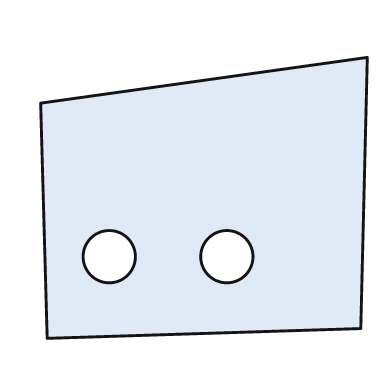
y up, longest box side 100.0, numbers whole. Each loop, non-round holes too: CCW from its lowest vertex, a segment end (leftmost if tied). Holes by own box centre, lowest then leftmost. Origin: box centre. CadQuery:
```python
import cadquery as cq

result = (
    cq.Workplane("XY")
    .moveTo(-48.0, -43.0)
    .lineTo(48.0, -40.0)
    .lineTo(50.0, 43.0)
    .lineTo(-50.0, 29.0)
    .close()
    .moveTo(-29.0, -18.0)
    .circle(8.0)
    .moveTo(7.0, -18.0)
    .circle(8.0)
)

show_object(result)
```